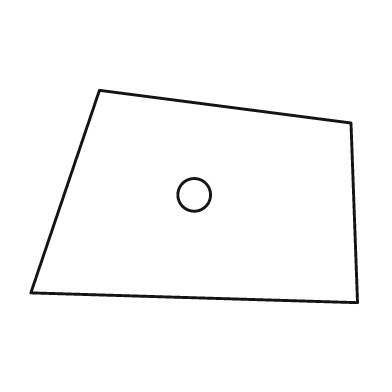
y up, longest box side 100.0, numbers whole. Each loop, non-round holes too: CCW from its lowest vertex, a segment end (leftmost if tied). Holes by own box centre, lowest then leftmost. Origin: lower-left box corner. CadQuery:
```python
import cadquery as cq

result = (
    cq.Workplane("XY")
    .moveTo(100.0, 0.0)
    .lineTo(98.0, 55.0)
    .lineTo(21.0, 65.0)
    .lineTo(0.0, 3.0)
    .close()
    .moveTo(50.0, 33.0)
    .circle(5.0)
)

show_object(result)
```